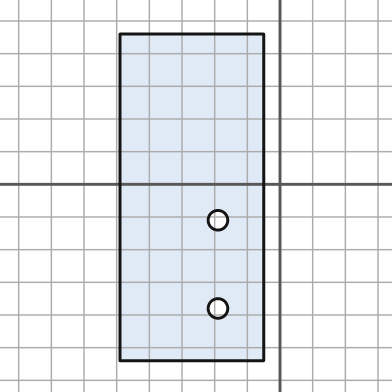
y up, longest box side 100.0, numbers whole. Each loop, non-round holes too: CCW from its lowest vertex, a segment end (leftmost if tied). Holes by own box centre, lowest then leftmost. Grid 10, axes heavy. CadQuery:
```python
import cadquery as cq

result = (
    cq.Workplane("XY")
    .moveTo(-49.0, -54.0)
    .lineTo(-5.0, -54.0)
    .lineTo(-5.0, 46.0)
    .lineTo(-49.0, 46.0)
    .close()
    .moveTo(-19.0, -38.0)
    .circle(3.0)
    .moveTo(-19.0, -11.0)
    .circle(3.0)
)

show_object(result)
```